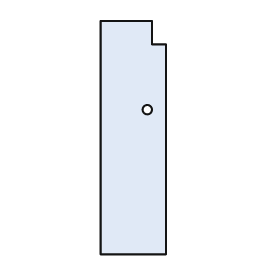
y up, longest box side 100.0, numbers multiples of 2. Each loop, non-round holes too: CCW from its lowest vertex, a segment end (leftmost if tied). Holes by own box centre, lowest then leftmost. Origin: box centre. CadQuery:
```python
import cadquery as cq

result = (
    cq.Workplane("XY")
    .moveTo(-14.0, -50.0)
    .lineTo(14.0, -50.0)
    .lineTo(14.0, 40.0)
    .lineTo(8.0, 40.0)
    .lineTo(8.0, 50.0)
    .lineTo(-14.0, 50.0)
    .close()
    .moveTo(6.0, 12.0)
    .circle(2.0)
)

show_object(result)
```